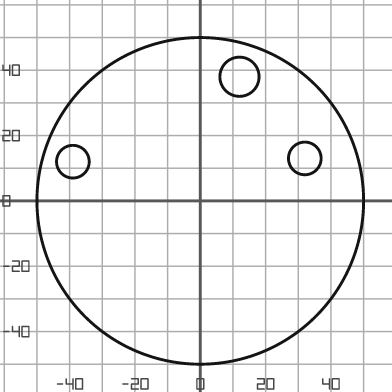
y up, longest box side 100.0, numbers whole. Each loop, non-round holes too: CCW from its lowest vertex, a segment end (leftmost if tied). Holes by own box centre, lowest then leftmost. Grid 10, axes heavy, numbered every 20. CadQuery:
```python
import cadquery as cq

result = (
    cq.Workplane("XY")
    .moveTo(0.0, 0.0)
    .circle(50.0)
    .moveTo(-39.0, 12.0)
    .circle(5.0)
    .moveTo(32.0, 13.0)
    .circle(5.0)
    .moveTo(12.0, 38.0)
    .circle(6.0)
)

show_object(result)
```